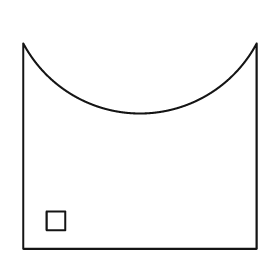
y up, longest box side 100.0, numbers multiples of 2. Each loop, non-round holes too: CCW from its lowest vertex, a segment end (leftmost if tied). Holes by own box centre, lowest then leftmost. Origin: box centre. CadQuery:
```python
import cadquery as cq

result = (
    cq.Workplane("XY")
    .moveTo(-50.0, -44.0)
    .lineTo(50.0, -44.0)
    .lineTo(50.0, 44.0)
    .threePointArc((0.0, 14.0), (-50.0, 44.0))
    .close()
    .moveTo(-40.0, -36.0)
    .lineTo(-32.0, -36.0)
    .lineTo(-32.0, -28.0)
    .lineTo(-40.0, -28.0)
    .close()
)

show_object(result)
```